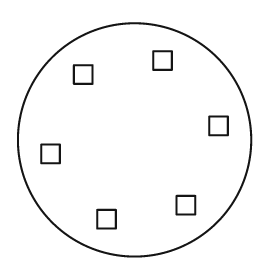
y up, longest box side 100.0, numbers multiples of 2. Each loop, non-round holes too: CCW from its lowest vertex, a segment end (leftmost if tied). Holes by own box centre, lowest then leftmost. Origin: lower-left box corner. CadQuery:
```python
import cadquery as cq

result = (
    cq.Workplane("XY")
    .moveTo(50.0, 50.0)
    .circle(50.0)
    .moveTo(34.0, 12.0)
    .lineTo(42.0, 12.0)
    .lineTo(42.0, 20.0)
    .lineTo(34.0, 20.0)
    .close()
    .moveTo(68.0, 18.0)
    .lineTo(76.0, 18.0)
    .lineTo(76.0, 26.0)
    .lineTo(68.0, 26.0)
    .close()
    .moveTo(10.0, 40.0)
    .lineTo(18.0, 40.0)
    .lineTo(18.0, 48.0)
    .lineTo(10.0, 48.0)
    .close()
    .moveTo(82.0, 52.0)
    .lineTo(90.0, 52.0)
    .lineTo(90.0, 60.0)
    .lineTo(82.0, 60.0)
    .close()
    .moveTo(24.0, 74.0)
    .lineTo(32.0, 74.0)
    .lineTo(32.0, 82.0)
    .lineTo(24.0, 82.0)
    .close()
    .moveTo(58.0, 80.0)
    .lineTo(66.0, 80.0)
    .lineTo(66.0, 88.0)
    .lineTo(58.0, 88.0)
    .close()
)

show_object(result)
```